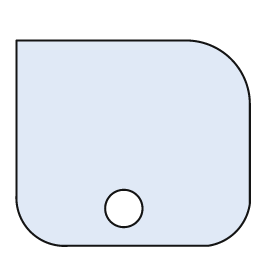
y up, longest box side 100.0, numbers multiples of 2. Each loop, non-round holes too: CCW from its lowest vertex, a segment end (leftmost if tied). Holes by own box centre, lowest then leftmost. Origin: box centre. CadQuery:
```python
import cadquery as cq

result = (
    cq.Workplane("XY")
    .moveTo(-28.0, -44.0)
    .lineTo(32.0, -44.0)
    .threePointArc((44.0, -38.0), (50.0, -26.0))
    .lineTo(50.0, 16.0)
    .threePointArc((42.0, 36.0), (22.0, 44.0))
    .lineTo(-50.0, 44.0)
    .lineTo(-50.0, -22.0)
    .threePointArc((-44.0, -38.0), (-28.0, -44.0))
    .close()
    .moveTo(-4.0, -28.0)
    .circle(8.0)
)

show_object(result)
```